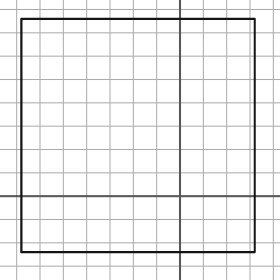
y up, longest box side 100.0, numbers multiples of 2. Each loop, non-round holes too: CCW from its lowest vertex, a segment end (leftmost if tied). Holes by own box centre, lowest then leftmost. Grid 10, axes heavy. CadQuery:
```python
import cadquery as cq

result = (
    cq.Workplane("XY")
    .moveTo(-68.0, -24.0)
    .lineTo(32.0, -24.0)
    .lineTo(32.0, 76.0)
    .lineTo(-68.0, 76.0)
    .close()
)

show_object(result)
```